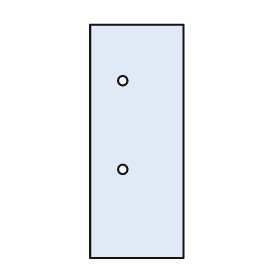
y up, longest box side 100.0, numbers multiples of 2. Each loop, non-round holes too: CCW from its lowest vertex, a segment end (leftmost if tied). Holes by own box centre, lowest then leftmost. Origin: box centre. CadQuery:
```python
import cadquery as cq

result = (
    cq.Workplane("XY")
    .moveTo(-20.0, -50.0)
    .lineTo(20.0, -50.0)
    .lineTo(20.0, 50.0)
    .lineTo(-20.0, 50.0)
    .close()
    .moveTo(-6.0, -12.0)
    .circle(2.0)
    .moveTo(-6.0, 26.0)
    .circle(2.0)
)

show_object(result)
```